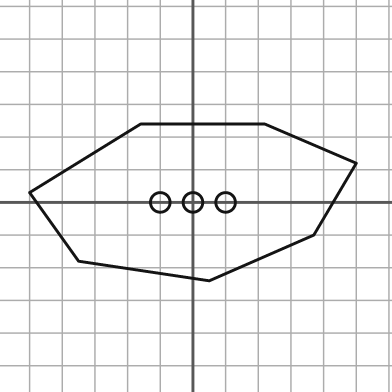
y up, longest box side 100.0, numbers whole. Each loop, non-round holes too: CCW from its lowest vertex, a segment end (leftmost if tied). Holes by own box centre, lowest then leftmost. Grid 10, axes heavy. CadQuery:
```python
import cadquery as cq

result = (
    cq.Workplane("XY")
    .moveTo(5.0, -24.0)
    .lineTo(37.0, -10.0)
    .lineTo(50.0, 12.0)
    .lineTo(22.0, 24.0)
    .lineTo(-16.0, 24.0)
    .lineTo(-50.0, 3.0)
    .lineTo(-35.0, -18.0)
    .close()
    .moveTo(-10.0, 0.0)
    .circle(3.0)
    .moveTo(0.0, 0.0)
    .circle(3.0)
    .moveTo(10.0, 0.0)
    .circle(3.0)
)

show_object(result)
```